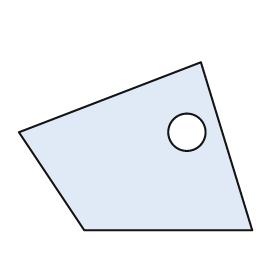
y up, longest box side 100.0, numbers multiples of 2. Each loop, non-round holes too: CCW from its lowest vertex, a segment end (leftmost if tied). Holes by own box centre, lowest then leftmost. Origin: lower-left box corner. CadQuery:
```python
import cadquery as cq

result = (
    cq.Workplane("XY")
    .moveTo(28.0, 0.0)
    .lineTo(100.0, 0.0)
    .lineTo(78.0, 72.0)
    .lineTo(0.0, 42.0)
    .close()
    .moveTo(72.0, 42.0)
    .circle(8.0)
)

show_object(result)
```